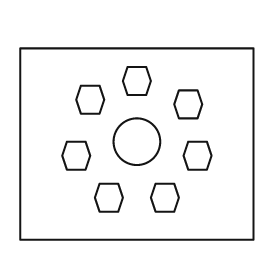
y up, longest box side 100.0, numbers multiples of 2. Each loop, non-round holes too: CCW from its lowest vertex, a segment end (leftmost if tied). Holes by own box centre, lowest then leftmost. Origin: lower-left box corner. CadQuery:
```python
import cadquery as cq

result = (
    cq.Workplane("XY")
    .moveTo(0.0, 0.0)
    .lineTo(100.0, 0.0)
    .lineTo(100.0, 82.0)
    .lineTo(0.0, 82.0)
    .close()
    .moveTo(34.0, 12.0)
    .lineTo(42.0, 12.0)
    .lineTo(44.0, 18.0)
    .lineTo(42.0, 24.0)
    .lineTo(34.0, 24.0)
    .lineTo(32.0, 18.0)
    .close()
    .moveTo(58.0, 12.0)
    .lineTo(66.0, 12.0)
    .lineTo(68.0, 18.0)
    .lineTo(66.0, 24.0)
    .lineTo(58.0, 24.0)
    .lineTo(56.0, 18.0)
    .close()
    .moveTo(20.0, 30.0)
    .lineTo(28.0, 30.0)
    .lineTo(30.0, 36.0)
    .lineTo(28.0, 42.0)
    .lineTo(20.0, 42.0)
    .lineTo(18.0, 36.0)
    .close()
    .moveTo(72.0, 30.0)
    .lineTo(80.0, 30.0)
    .lineTo(82.0, 36.0)
    .lineTo(80.0, 42.0)
    .lineTo(72.0, 42.0)
    .lineTo(70.0, 36.0)
    .close()
    .moveTo(50.0, 42.0)
    .circle(10.0)
    .moveTo(68.0, 52.0)
    .lineTo(76.0, 52.0)
    .lineTo(78.0, 58.0)
    .lineTo(76.0, 64.0)
    .lineTo(68.0, 64.0)
    .lineTo(66.0, 58.0)
    .close()
    .moveTo(26.0, 54.0)
    .lineTo(34.0, 54.0)
    .lineTo(36.0, 60.0)
    .lineTo(34.0, 66.0)
    .lineTo(26.0, 66.0)
    .lineTo(24.0, 60.0)
    .close()
    .moveTo(46.0, 62.0)
    .lineTo(54.0, 62.0)
    .lineTo(56.0, 68.0)
    .lineTo(54.0, 74.0)
    .lineTo(46.0, 74.0)
    .lineTo(44.0, 68.0)
    .close()
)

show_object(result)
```